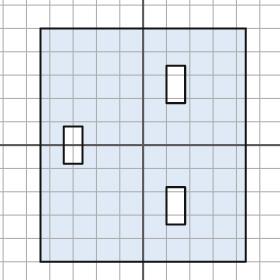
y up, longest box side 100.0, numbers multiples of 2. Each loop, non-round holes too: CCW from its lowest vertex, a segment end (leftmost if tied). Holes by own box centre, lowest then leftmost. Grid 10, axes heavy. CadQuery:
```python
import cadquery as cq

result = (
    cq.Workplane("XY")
    .moveTo(-44.0, -50.0)
    .lineTo(44.0, -50.0)
    .lineTo(44.0, 50.0)
    .lineTo(-44.0, 50.0)
    .close()
    .moveTo(10.0, -34.0)
    .lineTo(18.0, -34.0)
    .lineTo(18.0, -18.0)
    .lineTo(10.0, -18.0)
    .close()
    .moveTo(-34.0, -8.0)
    .lineTo(-26.0, -8.0)
    .lineTo(-26.0, 8.0)
    .lineTo(-34.0, 8.0)
    .close()
    .moveTo(10.0, 18.0)
    .lineTo(18.0, 18.0)
    .lineTo(18.0, 34.0)
    .lineTo(10.0, 34.0)
    .close()
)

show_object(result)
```